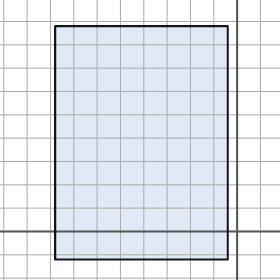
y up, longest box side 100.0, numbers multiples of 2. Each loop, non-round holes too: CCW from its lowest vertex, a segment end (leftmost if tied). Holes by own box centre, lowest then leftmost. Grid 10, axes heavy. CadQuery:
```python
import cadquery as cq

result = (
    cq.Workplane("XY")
    .moveTo(-78.0, -12.0)
    .lineTo(-4.0, -12.0)
    .lineTo(-4.0, 88.0)
    .lineTo(-78.0, 88.0)
    .close()
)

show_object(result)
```